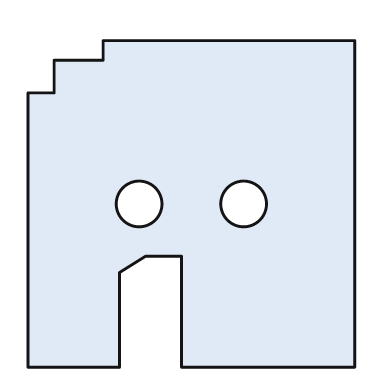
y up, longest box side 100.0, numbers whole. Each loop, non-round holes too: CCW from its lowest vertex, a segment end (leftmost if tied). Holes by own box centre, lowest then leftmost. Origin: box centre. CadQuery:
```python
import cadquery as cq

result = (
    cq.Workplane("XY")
    .moveTo(-50.0, -50.0)
    .lineTo(-22.0, -50.0)
    .lineTo(-22.0, -21.0)
    .lineTo(-14.0, -16.0)
    .lineTo(-3.0, -16.0)
    .lineTo(-3.0, -50.0)
    .lineTo(50.0, -50.0)
    .lineTo(50.0, 50.0)
    .lineTo(-27.0, 50.0)
    .lineTo(-27.0, 44.0)
    .lineTo(-42.0, 44.0)
    .lineTo(-42.0, 34.0)
    .lineTo(-50.0, 34.0)
    .close()
    .moveTo(-16.0, 0.0)
    .circle(7.0)
    .moveTo(16.0, 0.0)
    .circle(7.0)
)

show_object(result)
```